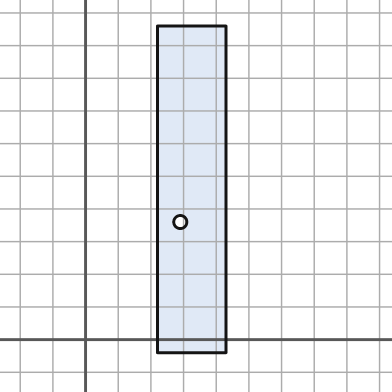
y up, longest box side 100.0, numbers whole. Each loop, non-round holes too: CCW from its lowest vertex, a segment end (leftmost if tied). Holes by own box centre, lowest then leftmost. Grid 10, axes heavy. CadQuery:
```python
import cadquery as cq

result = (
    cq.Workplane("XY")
    .moveTo(22.0, -4.0)
    .lineTo(43.0, -4.0)
    .lineTo(43.0, 96.0)
    .lineTo(22.0, 96.0)
    .close()
    .moveTo(29.0, 36.0)
    .circle(2.0)
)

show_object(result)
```